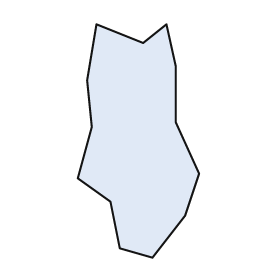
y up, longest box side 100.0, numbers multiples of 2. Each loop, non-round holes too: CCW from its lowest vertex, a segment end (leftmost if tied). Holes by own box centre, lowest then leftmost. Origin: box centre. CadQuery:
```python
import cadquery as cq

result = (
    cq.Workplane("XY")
    .moveTo(6.0, -50.0)
    .lineTo(20.0, -32.0)
    .lineTo(26.0, -14.0)
    .lineTo(16.0, 8.0)
    .lineTo(16.0, 32.0)
    .lineTo(12.0, 50.0)
    .lineTo(2.0, 42.0)
    .lineTo(-18.0, 50.0)
    .lineTo(-22.0, 26.0)
    .lineTo(-20.0, 6.0)
    .lineTo(-26.0, -16.0)
    .lineTo(-12.0, -26.0)
    .lineTo(-8.0, -46.0)
    .close()
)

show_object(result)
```